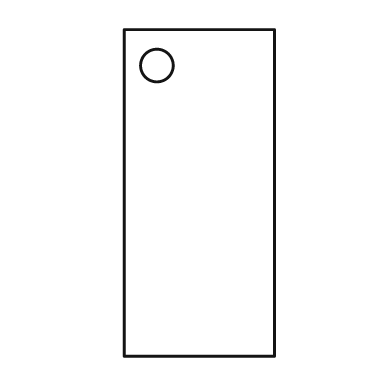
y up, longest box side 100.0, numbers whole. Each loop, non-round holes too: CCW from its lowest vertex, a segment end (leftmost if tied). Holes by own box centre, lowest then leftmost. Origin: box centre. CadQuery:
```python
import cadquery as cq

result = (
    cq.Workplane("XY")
    .moveTo(-23.0, -50.0)
    .lineTo(23.0, -50.0)
    .lineTo(23.0, 50.0)
    .lineTo(-23.0, 50.0)
    .close()
    .moveTo(-13.0, 39.0)
    .circle(5.0)
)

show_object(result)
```